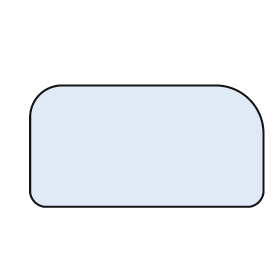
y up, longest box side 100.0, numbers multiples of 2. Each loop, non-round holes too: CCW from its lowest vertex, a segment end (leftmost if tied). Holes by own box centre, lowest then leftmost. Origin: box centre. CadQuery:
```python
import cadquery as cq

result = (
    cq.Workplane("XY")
    .moveTo(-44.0, -26.0)
    .lineTo(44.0, -26.0)
    .threePointArc((48.0, -24.0), (50.0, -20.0))
    .lineTo(50.0, 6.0)
    .threePointArc((44.0, 20.0), (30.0, 26.0))
    .lineTo(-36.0, 26.0)
    .threePointArc((-46.0, 22.0), (-50.0, 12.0))
    .lineTo(-50.0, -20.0)
    .threePointArc((-48.0, -24.0), (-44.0, -26.0))
    .close()
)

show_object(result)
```